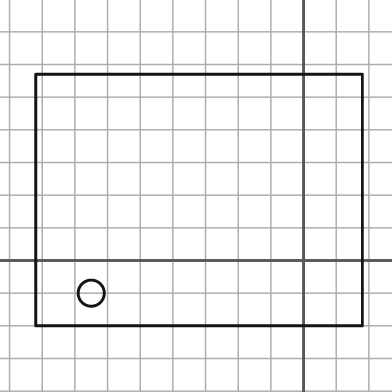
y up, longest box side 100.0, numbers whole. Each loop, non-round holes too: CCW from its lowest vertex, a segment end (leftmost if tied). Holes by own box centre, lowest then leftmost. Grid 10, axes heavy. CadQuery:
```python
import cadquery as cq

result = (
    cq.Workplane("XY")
    .moveTo(-82.0, -20.0)
    .lineTo(18.0, -20.0)
    .lineTo(18.0, 57.0)
    .lineTo(-82.0, 57.0)
    .close()
    .moveTo(-65.0, -10.0)
    .circle(4.0)
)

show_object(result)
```